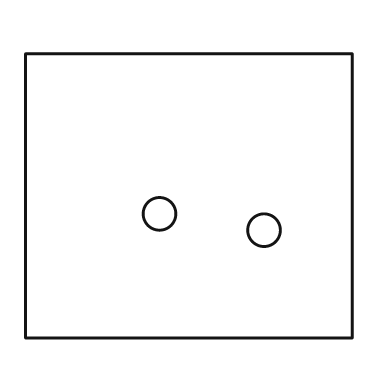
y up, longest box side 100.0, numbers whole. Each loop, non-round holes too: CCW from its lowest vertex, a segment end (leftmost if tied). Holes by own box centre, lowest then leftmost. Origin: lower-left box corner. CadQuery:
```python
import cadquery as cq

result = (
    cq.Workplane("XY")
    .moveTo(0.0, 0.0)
    .lineTo(100.0, 0.0)
    .lineTo(100.0, 87.0)
    .lineTo(0.0, 87.0)
    .close()
    .moveTo(73.0, 33.0)
    .circle(5.0)
    .moveTo(41.0, 38.0)
    .circle(5.0)
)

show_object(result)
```